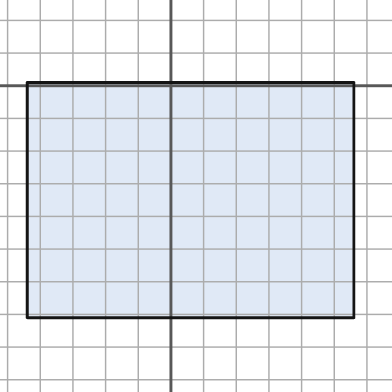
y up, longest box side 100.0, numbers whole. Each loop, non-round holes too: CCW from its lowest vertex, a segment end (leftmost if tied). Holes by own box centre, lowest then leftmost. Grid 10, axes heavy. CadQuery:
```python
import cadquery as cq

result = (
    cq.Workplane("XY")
    .moveTo(-44.0, -71.0)
    .lineTo(56.0, -71.0)
    .lineTo(56.0, 1.0)
    .lineTo(-44.0, 1.0)
    .close()
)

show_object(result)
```